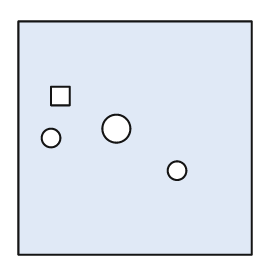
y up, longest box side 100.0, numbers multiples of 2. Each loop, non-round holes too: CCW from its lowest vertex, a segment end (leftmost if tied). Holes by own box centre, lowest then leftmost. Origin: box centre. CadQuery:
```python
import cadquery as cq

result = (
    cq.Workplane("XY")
    .moveTo(-50.0, -50.0)
    .lineTo(50.0, -50.0)
    .lineTo(50.0, 50.0)
    .lineTo(-50.0, 50.0)
    .close()
    .moveTo(18.0, -14.0)
    .circle(4.0)
    .moveTo(-36.0, 0.0)
    .circle(4.0)
    .moveTo(-8.0, 4.0)
    .circle(6.0)
    .moveTo(-36.0, 14.0)
    .lineTo(-28.0, 14.0)
    .lineTo(-28.0, 22.0)
    .lineTo(-36.0, 22.0)
    .close()
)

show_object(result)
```